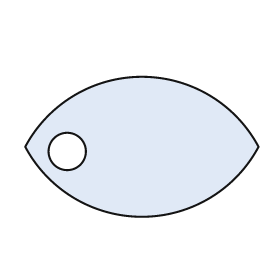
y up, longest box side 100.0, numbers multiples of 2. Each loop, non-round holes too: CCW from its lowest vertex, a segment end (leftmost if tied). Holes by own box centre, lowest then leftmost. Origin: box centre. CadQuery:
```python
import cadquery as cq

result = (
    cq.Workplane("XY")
    .moveTo(-50.0, 0.0)
    .threePointArc((0.0, -30.0), (50.0, 0.0))
    .threePointArc((0.0, 30.0), (-50.0, 0.0))
    .close()
    .moveTo(-32.0, -2.0)
    .circle(8.0)
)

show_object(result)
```